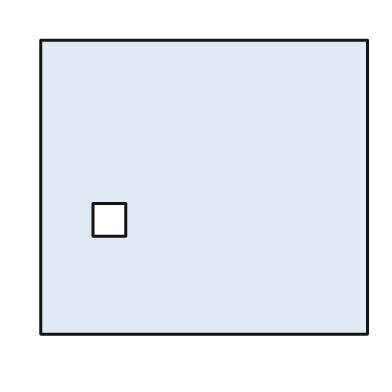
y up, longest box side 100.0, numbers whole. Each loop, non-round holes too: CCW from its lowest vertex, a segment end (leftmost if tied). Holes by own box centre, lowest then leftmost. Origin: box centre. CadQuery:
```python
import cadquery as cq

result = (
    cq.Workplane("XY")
    .moveTo(-50.0, -45.0)
    .lineTo(50.0, -45.0)
    .lineTo(50.0, 45.0)
    .lineTo(-50.0, 45.0)
    .close()
    .moveTo(-34.0, -15.0)
    .lineTo(-24.0, -15.0)
    .lineTo(-24.0, -5.0)
    .lineTo(-34.0, -5.0)
    .close()
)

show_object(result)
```